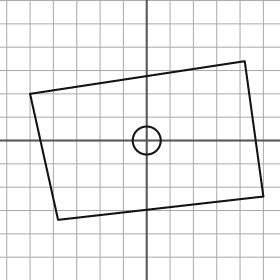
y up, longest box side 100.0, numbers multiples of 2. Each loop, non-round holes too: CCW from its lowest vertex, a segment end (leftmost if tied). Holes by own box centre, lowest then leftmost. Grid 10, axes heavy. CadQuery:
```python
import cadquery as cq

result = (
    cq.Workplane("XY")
    .moveTo(-38.0, -34.0)
    .lineTo(50.0, -24.0)
    .lineTo(42.0, 34.0)
    .lineTo(-50.0, 20.0)
    .close()
    .moveTo(0.0, 0.0)
    .circle(6.0)
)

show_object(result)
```